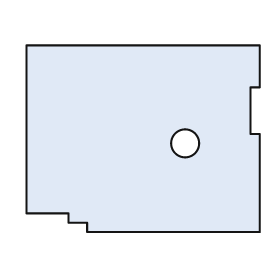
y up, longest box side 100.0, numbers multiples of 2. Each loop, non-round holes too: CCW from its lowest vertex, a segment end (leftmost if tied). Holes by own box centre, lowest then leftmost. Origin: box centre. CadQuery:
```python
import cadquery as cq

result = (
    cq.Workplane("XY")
    .moveTo(-24.0, -40.0)
    .lineTo(50.0, -40.0)
    .lineTo(50.0, 2.0)
    .lineTo(46.0, 2.0)
    .lineTo(46.0, 22.0)
    .lineTo(50.0, 22.0)
    .lineTo(50.0, 40.0)
    .lineTo(-50.0, 40.0)
    .lineTo(-50.0, -32.0)
    .lineTo(-32.0, -32.0)
    .lineTo(-32.0, -36.0)
    .lineTo(-24.0, -36.0)
    .close()
    .moveTo(18.0, -2.0)
    .circle(6.0)
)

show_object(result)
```